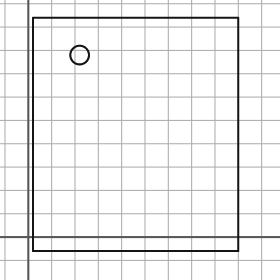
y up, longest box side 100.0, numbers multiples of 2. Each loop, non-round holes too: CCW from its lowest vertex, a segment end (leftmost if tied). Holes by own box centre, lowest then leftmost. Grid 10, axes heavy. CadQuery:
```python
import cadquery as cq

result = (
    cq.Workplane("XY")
    .moveTo(2.0, -6.0)
    .lineTo(90.0, -6.0)
    .lineTo(90.0, 94.0)
    .lineTo(2.0, 94.0)
    .close()
    .moveTo(22.0, 78.0)
    .circle(4.0)
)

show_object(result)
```